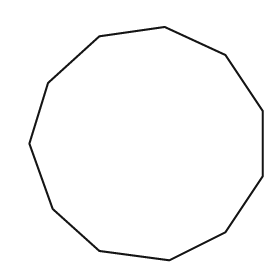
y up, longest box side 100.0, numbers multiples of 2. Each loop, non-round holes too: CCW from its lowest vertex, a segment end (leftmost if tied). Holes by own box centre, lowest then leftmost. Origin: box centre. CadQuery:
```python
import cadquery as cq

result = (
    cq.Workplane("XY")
    .moveTo(10.0, -50.0)
    .lineTo(34.0, -38.0)
    .lineTo(50.0, -14.0)
    .lineTo(50.0, 14.0)
    .lineTo(34.0, 38.0)
    .lineTo(8.0, 50.0)
    .lineTo(-20.0, 46.0)
    .lineTo(-42.0, 26.0)
    .lineTo(-50.0, 0.0)
    .lineTo(-40.0, -28.0)
    .lineTo(-20.0, -46.0)
    .close()
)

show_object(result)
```